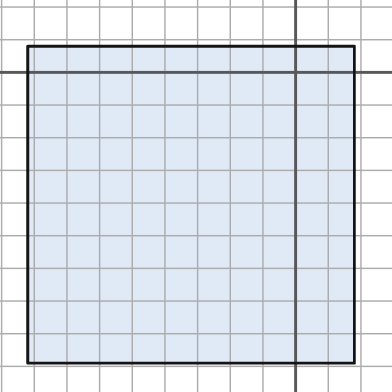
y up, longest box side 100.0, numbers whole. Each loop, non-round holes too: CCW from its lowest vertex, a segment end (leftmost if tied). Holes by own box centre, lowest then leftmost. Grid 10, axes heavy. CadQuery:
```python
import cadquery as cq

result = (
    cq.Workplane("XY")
    .moveTo(-82.0, -89.0)
    .lineTo(18.0, -89.0)
    .lineTo(18.0, 8.0)
    .lineTo(-82.0, 8.0)
    .close()
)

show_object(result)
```